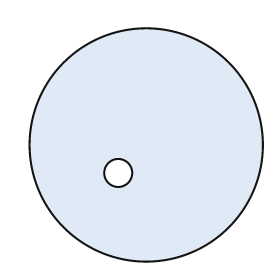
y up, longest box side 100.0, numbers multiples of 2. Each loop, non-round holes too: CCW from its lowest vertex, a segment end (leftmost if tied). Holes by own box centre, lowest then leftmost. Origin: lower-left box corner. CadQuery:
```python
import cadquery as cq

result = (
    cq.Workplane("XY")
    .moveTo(50.0, 50.0)
    .circle(50.0)
    .moveTo(38.0, 38.0)
    .circle(6.0)
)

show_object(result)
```